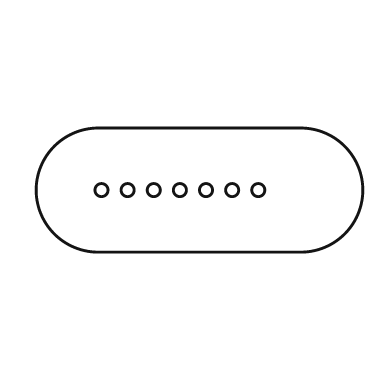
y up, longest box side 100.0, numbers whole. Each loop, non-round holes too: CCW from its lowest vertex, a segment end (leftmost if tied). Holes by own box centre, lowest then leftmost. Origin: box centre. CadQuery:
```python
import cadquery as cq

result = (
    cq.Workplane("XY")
    .moveTo(-31.0, -19.0)
    .lineTo(31.0, -19.0)
    .threePointArc((50.0, 0.0), (31.0, 19.0))
    .lineTo(-31.0, 19.0)
    .threePointArc((-50.0, 0.0), (-31.0, -19.0))
    .close()
    .moveTo(-30.0, 0.0)
    .circle(2.0)
    .moveTo(-22.0, 0.0)
    .circle(2.0)
    .moveTo(-14.0, 0.0)
    .circle(2.0)
    .moveTo(-6.0, 0.0)
    .circle(2.0)
    .moveTo(2.0, 0.0)
    .circle(2.0)
    .moveTo(10.0, 0.0)
    .circle(2.0)
    .moveTo(18.0, 0.0)
    .circle(2.0)
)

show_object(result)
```